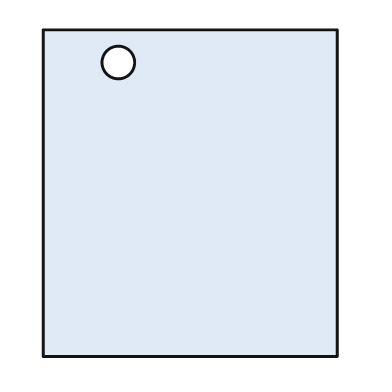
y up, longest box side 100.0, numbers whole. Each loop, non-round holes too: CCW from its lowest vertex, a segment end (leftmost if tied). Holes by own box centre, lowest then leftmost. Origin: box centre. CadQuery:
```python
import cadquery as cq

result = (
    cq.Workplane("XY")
    .moveTo(-45.0, -50.0)
    .lineTo(45.0, -50.0)
    .lineTo(45.0, 50.0)
    .lineTo(-45.0, 50.0)
    .close()
    .moveTo(-22.0, 40.0)
    .circle(5.0)
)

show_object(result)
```